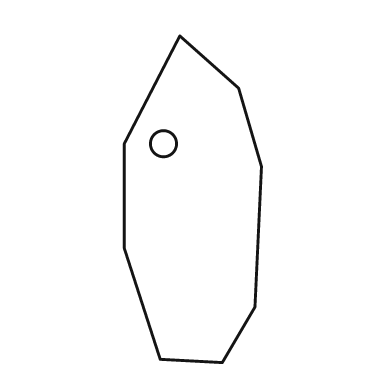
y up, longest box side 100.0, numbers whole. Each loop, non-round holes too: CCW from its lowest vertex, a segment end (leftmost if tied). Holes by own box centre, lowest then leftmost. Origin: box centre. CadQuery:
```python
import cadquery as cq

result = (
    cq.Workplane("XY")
    .moveTo(9.0, -50.0)
    .lineTo(19.0, -33.0)
    .lineTo(21.0, 10.0)
    .lineTo(14.0, 34.0)
    .lineTo(-4.0, 50.0)
    .lineTo(-21.0, 17.0)
    .lineTo(-21.0, -15.0)
    .lineTo(-10.0, -49.0)
    .close()
    .moveTo(-9.0, 17.0)
    .circle(4.0)
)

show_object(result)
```